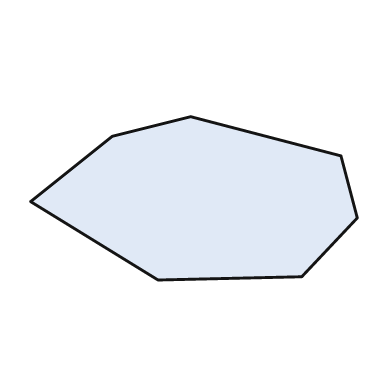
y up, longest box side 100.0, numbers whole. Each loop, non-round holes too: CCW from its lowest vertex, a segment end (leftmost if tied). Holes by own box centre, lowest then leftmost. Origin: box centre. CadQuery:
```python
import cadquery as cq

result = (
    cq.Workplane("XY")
    .moveTo(-11.0, -25.0)
    .lineTo(33.0, -24.0)
    .lineTo(50.0, -6.0)
    .lineTo(45.0, 13.0)
    .lineTo(-1.0, 25.0)
    .lineTo(-25.0, 19.0)
    .lineTo(-50.0, -1.0)
    .close()
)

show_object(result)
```